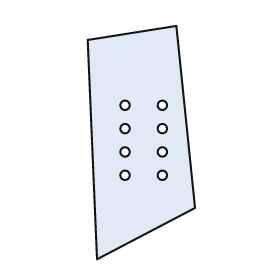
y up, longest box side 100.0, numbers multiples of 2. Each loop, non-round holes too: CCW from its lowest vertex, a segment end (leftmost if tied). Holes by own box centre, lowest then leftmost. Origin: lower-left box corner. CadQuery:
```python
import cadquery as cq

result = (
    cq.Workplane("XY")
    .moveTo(4.0, 0.0)
    .lineTo(46.0, 22.0)
    .lineTo(38.0, 100.0)
    .lineTo(0.0, 94.0)
    .close()
    .moveTo(16.0, 36.0)
    .circle(2.0)
    .moveTo(32.0, 36.0)
    .circle(2.0)
    .moveTo(16.0, 46.0)
    .circle(2.0)
    .moveTo(32.0, 46.0)
    .circle(2.0)
    .moveTo(16.0, 56.0)
    .circle(2.0)
    .moveTo(32.0, 56.0)
    .circle(2.0)
    .moveTo(16.0, 66.0)
    .circle(2.0)
    .moveTo(32.0, 66.0)
    .circle(2.0)
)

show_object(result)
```